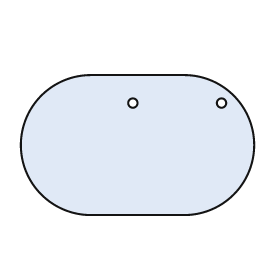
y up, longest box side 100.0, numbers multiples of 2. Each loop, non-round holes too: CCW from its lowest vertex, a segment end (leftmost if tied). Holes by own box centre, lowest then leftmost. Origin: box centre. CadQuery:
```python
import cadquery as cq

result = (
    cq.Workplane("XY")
    .moveTo(-20.0, -30.0)
    .lineTo(20.0, -30.0)
    .threePointArc((50.0, 0.0), (20.0, 30.0))
    .lineTo(-20.0, 30.0)
    .threePointArc((-50.0, 0.0), (-20.0, -30.0))
    .close()
    .moveTo(-2.0, 18.0)
    .circle(2.0)
    .moveTo(36.0, 18.0)
    .circle(2.0)
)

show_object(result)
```